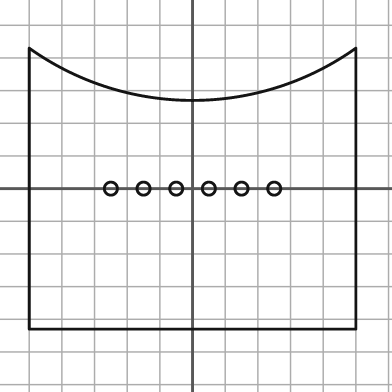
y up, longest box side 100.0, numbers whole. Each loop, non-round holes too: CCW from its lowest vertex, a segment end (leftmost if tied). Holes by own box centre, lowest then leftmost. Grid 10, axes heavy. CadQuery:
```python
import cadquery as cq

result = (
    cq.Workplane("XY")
    .moveTo(-50.0, -43.0)
    .lineTo(50.0, -43.0)
    .lineTo(50.0, 43.0)
    .threePointArc((0.0, 27.0), (-50.0, 43.0))
    .close()
    .moveTo(-25.0, 0.0)
    .circle(2.0)
    .moveTo(-15.0, 0.0)
    .circle(2.0)
    .moveTo(-5.0, 0.0)
    .circle(2.0)
    .moveTo(5.0, 0.0)
    .circle(2.0)
    .moveTo(15.0, 0.0)
    .circle(2.0)
    .moveTo(25.0, 0.0)
    .circle(2.0)
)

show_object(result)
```